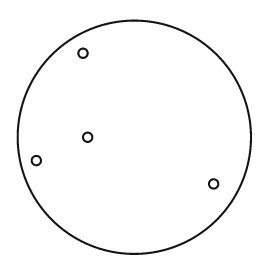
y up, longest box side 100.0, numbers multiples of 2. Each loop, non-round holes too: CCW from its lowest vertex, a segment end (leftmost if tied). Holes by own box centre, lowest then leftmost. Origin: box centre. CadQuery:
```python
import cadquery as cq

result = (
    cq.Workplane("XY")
    .moveTo(0.0, 0.0)
    .circle(50.0)
    .moveTo(34.0, -20.0)
    .circle(2.0)
    .moveTo(-42.0, -10.0)
    .circle(2.0)
    .moveTo(-20.0, 0.0)
    .circle(2.0)
    .moveTo(-22.0, 36.0)
    .circle(2.0)
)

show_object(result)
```